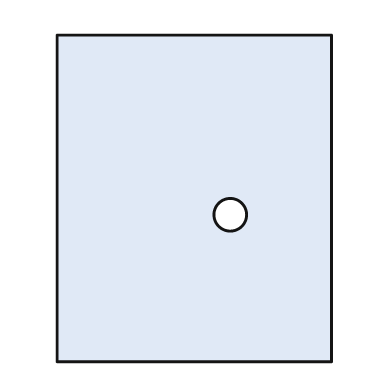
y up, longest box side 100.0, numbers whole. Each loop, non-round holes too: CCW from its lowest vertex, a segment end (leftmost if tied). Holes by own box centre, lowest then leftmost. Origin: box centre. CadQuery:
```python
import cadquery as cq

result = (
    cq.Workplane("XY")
    .moveTo(-42.0, -50.0)
    .lineTo(42.0, -50.0)
    .lineTo(42.0, 50.0)
    .lineTo(-42.0, 50.0)
    .close()
    .moveTo(11.0, -5.0)
    .circle(5.0)
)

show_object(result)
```